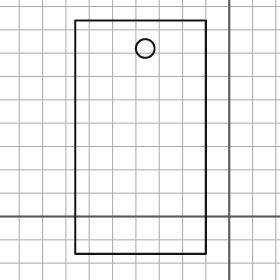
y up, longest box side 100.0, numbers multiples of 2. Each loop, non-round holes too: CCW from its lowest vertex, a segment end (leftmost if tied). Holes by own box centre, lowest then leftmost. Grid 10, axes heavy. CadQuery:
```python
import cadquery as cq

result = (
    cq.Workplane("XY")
    .moveTo(-66.0, -16.0)
    .lineTo(-10.0, -16.0)
    .lineTo(-10.0, 84.0)
    .lineTo(-66.0, 84.0)
    .close()
    .moveTo(-36.0, 72.0)
    .circle(4.0)
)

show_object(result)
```